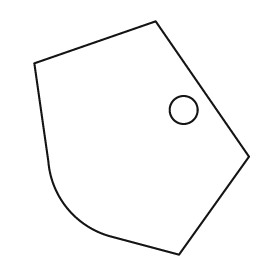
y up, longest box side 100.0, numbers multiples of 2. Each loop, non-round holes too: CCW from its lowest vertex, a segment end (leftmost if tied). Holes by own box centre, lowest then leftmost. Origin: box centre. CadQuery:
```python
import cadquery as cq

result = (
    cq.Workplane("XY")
    .moveTo(16.0, -50.0)
    .lineTo(46.0, -8.0)
    .lineTo(6.0, 50.0)
    .lineTo(-46.0, 32.0)
    .lineTo(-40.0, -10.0)
    .threePointArc((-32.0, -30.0), (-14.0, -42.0))
    .close()
    .moveTo(18.0, 12.0)
    .circle(6.0)
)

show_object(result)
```